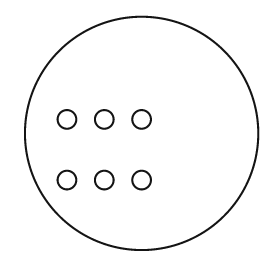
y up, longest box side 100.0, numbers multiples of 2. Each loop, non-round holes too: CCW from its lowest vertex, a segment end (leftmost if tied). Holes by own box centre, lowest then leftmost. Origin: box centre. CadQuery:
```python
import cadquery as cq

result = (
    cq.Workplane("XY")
    .moveTo(0.0, 0.0)
    .circle(50.0)
    .moveTo(-32.0, -20.0)
    .circle(4.0)
    .moveTo(-16.0, -20.0)
    .circle(4.0)
    .moveTo(0.0, -20.0)
    .circle(4.0)
    .moveTo(-32.0, 6.0)
    .circle(4.0)
    .moveTo(-16.0, 6.0)
    .circle(4.0)
    .moveTo(0.0, 6.0)
    .circle(4.0)
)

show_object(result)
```